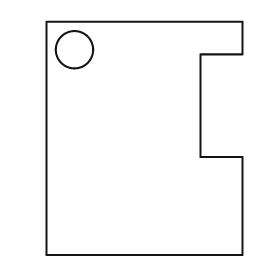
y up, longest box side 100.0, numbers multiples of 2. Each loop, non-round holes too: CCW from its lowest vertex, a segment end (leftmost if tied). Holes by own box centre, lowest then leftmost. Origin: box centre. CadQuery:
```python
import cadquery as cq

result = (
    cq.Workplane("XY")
    .moveTo(-42.0, -50.0)
    .lineTo(42.0, -50.0)
    .lineTo(42.0, -8.0)
    .lineTo(24.0, -8.0)
    .lineTo(24.0, 36.0)
    .lineTo(42.0, 36.0)
    .lineTo(42.0, 50.0)
    .lineTo(-42.0, 50.0)
    .close()
    .moveTo(-30.0, 38.0)
    .circle(8.0)
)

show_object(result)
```